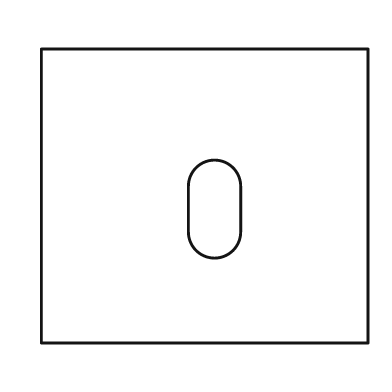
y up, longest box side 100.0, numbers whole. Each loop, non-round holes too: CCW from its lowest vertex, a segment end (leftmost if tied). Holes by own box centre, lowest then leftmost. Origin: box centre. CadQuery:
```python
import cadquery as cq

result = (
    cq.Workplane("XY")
    .moveTo(-50.0, -45.0)
    .lineTo(50.0, -45.0)
    .lineTo(50.0, 45.0)
    .lineTo(-50.0, 45.0)
    .close()
    .moveTo(-5.0, -11.0)
    .threePointArc((3.0, -19.0), (11.0, -11.0))
    .lineTo(11.0, 3.0)
    .threePointArc((3.0, 11.0), (-5.0, 3.0))
    .close()
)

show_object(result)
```